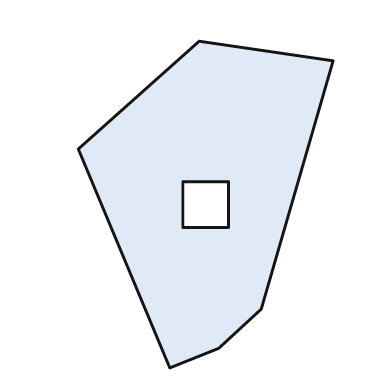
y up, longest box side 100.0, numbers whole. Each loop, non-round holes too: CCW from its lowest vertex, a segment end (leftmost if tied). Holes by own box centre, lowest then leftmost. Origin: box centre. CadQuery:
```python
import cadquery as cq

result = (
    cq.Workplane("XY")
    .moveTo(-11.0, -50.0)
    .lineTo(4.0, -44.0)
    .lineTo(17.0, -32.0)
    .lineTo(39.0, 44.0)
    .lineTo(-2.0, 50.0)
    .lineTo(-39.0, 17.0)
    .close()
    .moveTo(-7.0, -7.0)
    .lineTo(7.0, -7.0)
    .lineTo(7.0, 7.0)
    .lineTo(-7.0, 7.0)
    .close()
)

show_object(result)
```